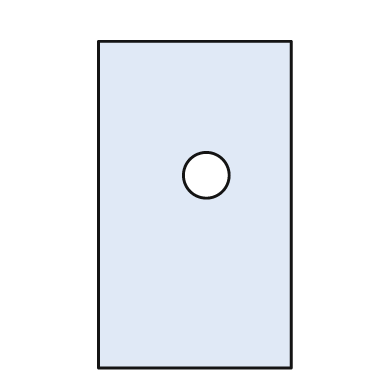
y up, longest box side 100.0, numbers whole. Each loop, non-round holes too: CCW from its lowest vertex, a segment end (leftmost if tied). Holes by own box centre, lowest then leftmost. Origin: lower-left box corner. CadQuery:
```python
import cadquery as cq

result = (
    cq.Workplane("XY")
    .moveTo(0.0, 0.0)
    .lineTo(59.0, 0.0)
    .lineTo(59.0, 100.0)
    .lineTo(0.0, 100.0)
    .close()
    .moveTo(33.0, 59.0)
    .circle(7.0)
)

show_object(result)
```